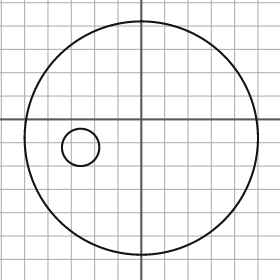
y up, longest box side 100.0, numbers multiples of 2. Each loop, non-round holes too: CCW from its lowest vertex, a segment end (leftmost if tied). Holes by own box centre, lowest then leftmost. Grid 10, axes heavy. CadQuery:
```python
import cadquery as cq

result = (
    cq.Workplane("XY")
    .moveTo(0.0, -8.0)
    .circle(50.0)
    .moveTo(-26.0, -12.0)
    .circle(8.0)
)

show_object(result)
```